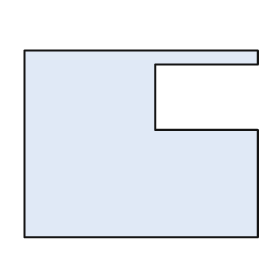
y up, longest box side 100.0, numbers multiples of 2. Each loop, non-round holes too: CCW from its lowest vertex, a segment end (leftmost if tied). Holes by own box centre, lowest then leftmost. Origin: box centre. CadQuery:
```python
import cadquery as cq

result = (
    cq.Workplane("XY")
    .moveTo(-50.0, -40.0)
    .lineTo(50.0, -40.0)
    .lineTo(50.0, 6.0)
    .lineTo(6.0, 6.0)
    .lineTo(6.0, 34.0)
    .lineTo(50.0, 34.0)
    .lineTo(50.0, 40.0)
    .lineTo(-50.0, 40.0)
    .close()
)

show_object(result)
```